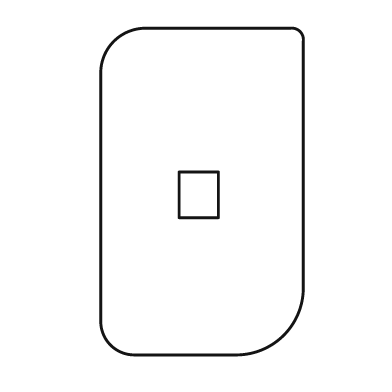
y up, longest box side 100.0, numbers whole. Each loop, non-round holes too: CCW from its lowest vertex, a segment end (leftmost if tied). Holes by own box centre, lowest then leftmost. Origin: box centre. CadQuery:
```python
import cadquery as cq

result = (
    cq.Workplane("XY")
    .moveTo(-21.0, -50.0)
    .lineTo(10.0, -50.0)
    .threePointArc((25.0, -44.0), (31.0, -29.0))
    .lineTo(31.0, 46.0)
    .threePointArc((30.0, 49.0), (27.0, 50.0))
    .lineTo(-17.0, 50.0)
    .threePointArc((-27.0, 46.0), (-31.0, 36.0))
    .lineTo(-31.0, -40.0)
    .threePointArc((-28.0, -47.0), (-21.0, -50.0))
    .close()
    .moveTo(-7.0, -8.0)
    .lineTo(5.0, -8.0)
    .lineTo(5.0, 6.0)
    .lineTo(-7.0, 6.0)
    .close()
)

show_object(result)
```